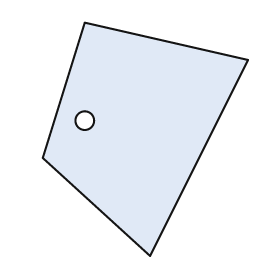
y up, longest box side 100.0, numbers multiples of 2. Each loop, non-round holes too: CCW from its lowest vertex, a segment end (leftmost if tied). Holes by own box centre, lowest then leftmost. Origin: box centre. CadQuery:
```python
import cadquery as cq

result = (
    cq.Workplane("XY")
    .moveTo(2.0, -50.0)
    .lineTo(44.0, 34.0)
    .lineTo(-26.0, 50.0)
    .lineTo(-44.0, -8.0)
    .close()
    .moveTo(-26.0, 8.0)
    .circle(4.0)
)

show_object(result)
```